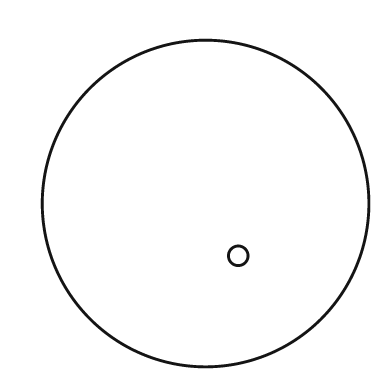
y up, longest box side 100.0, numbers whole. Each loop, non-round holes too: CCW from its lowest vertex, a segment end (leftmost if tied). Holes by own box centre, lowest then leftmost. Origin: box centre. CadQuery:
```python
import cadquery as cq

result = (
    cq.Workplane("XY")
    .moveTo(0.0, 0.0)
    .circle(50.0)
    .moveTo(10.0, -16.0)
    .circle(3.0)
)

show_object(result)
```